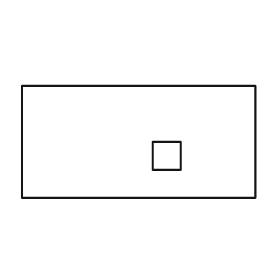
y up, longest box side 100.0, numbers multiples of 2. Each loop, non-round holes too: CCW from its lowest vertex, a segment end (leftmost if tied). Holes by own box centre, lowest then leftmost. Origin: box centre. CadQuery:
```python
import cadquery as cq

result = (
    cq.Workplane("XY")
    .moveTo(-50.0, -24.0)
    .lineTo(50.0, -24.0)
    .lineTo(50.0, 24.0)
    .lineTo(-50.0, 24.0)
    .close()
    .moveTo(6.0, -12.0)
    .lineTo(18.0, -12.0)
    .lineTo(18.0, 0.0)
    .lineTo(6.0, 0.0)
    .close()
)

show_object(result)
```